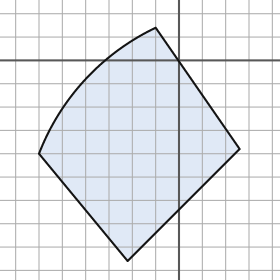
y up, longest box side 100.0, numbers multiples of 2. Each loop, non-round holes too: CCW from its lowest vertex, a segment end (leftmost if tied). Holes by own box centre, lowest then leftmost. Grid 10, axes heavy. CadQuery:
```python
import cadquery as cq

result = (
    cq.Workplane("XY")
    .moveTo(-22.0, -86.0)
    .lineTo(26.0, -38.0)
    .lineTo(-10.0, 14.0)
    .threePointArc((-40.0, -8.0), (-60.0, -40.0))
    .close()
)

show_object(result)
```